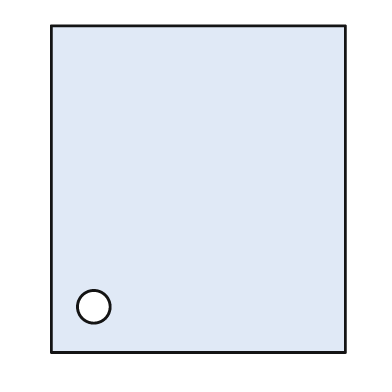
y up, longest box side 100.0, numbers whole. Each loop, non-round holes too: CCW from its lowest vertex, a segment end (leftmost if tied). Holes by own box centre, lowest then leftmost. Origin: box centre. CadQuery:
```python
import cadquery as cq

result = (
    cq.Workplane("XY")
    .moveTo(-45.0, -50.0)
    .lineTo(45.0, -50.0)
    .lineTo(45.0, 50.0)
    .lineTo(-45.0, 50.0)
    .close()
    .moveTo(-32.0, -36.0)
    .circle(5.0)
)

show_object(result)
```